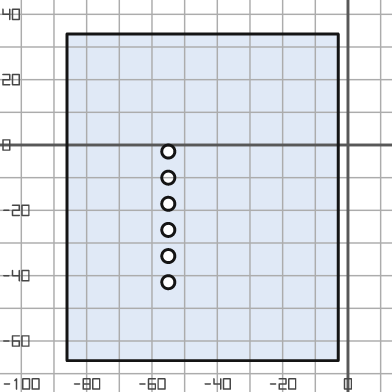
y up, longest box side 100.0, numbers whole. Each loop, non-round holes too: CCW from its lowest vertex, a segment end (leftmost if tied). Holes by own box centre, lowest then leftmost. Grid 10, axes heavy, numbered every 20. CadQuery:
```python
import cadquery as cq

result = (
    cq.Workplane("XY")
    .moveTo(-86.0, -66.0)
    .lineTo(-3.0, -66.0)
    .lineTo(-3.0, 34.0)
    .lineTo(-86.0, 34.0)
    .close()
    .moveTo(-55.0, -42.0)
    .circle(2.0)
    .moveTo(-55.0, -34.0)
    .circle(2.0)
    .moveTo(-55.0, -26.0)
    .circle(2.0)
    .moveTo(-55.0, -18.0)
    .circle(2.0)
    .moveTo(-55.0, -10.0)
    .circle(2.0)
    .moveTo(-55.0, -2.0)
    .circle(2.0)
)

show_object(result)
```